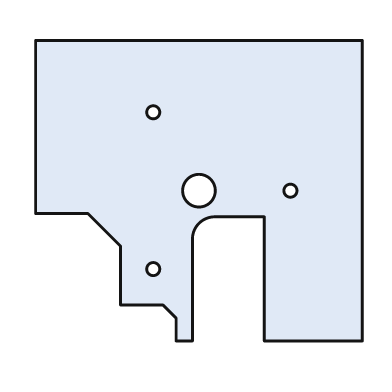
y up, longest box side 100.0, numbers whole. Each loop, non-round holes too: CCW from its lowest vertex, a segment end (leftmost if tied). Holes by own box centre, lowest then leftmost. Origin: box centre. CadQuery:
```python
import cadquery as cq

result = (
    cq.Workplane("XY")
    .moveTo(-7.0, -46.0)
    .lineTo(-2.0, -46.0)
    .lineTo(-2.0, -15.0)
    .threePointArc((0.0, -10.0), (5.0, -8.0))
    .lineTo(20.0, -8.0)
    .lineTo(20.0, -46.0)
    .lineTo(50.0, -46.0)
    .lineTo(50.0, 46.0)
    .lineTo(-50.0, 46.0)
    .lineTo(-50.0, -7.0)
    .lineTo(-34.0, -7.0)
    .lineTo(-24.0, -17.0)
    .lineTo(-24.0, -35.0)
    .lineTo(-11.0, -35.0)
    .lineTo(-7.0, -39.0)
    .close()
    .moveTo(-14.0, -24.0)
    .circle(2.0)
    .moveTo(0.0, 0.0)
    .circle(5.0)
    .moveTo(28.0, 0.0)
    .circle(2.0)
    .moveTo(-14.0, 24.0)
    .circle(2.0)
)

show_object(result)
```